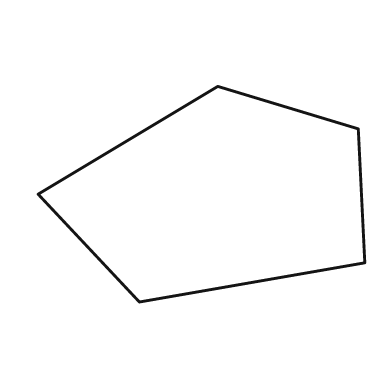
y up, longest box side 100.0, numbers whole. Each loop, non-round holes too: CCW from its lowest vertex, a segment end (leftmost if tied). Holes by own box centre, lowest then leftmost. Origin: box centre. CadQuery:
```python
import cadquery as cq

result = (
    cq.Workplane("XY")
    .moveTo(-19.0, -33.0)
    .lineTo(50.0, -21.0)
    .lineTo(48.0, 20.0)
    .lineTo(5.0, 33.0)
    .lineTo(-50.0, 0.0)
    .close()
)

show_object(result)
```